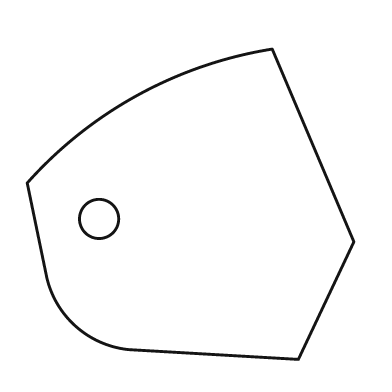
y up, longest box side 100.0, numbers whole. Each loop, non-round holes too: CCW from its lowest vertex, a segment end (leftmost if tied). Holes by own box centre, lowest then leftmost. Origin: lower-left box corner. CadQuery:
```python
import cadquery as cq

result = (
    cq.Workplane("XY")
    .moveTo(83.0, 0.0)
    .lineTo(100.0, 36.0)
    .lineTo(75.0, 95.0)
    .threePointArc((34.0, 81.0), (0.0, 54.0))
    .lineTo(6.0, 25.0)
    .threePointArc((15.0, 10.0), (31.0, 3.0))
    .close()
    .moveTo(22.0, 43.0)
    .circle(6.0)
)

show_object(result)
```